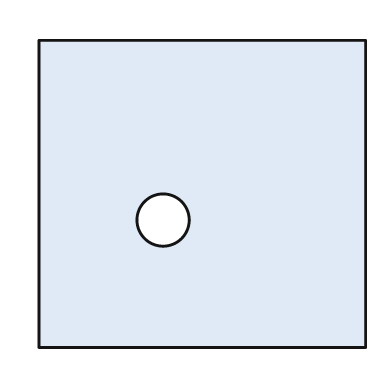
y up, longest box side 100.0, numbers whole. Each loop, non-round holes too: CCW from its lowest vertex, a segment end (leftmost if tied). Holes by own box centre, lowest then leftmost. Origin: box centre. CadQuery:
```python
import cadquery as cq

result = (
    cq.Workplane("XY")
    .moveTo(-50.0, -47.0)
    .lineTo(50.0, -47.0)
    .lineTo(50.0, 47.0)
    .lineTo(-50.0, 47.0)
    .close()
    .moveTo(-12.0, -8.0)
    .circle(8.0)
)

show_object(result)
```